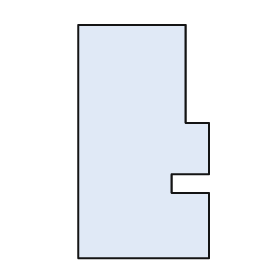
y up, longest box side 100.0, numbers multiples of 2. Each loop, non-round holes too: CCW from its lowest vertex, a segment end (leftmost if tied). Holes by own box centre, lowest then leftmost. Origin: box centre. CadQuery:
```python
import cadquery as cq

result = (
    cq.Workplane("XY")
    .moveTo(-28.0, -50.0)
    .lineTo(28.0, -50.0)
    .lineTo(28.0, -22.0)
    .lineTo(12.0, -22.0)
    .lineTo(12.0, -14.0)
    .lineTo(28.0, -14.0)
    .lineTo(28.0, 8.0)
    .lineTo(18.0, 8.0)
    .lineTo(18.0, 50.0)
    .lineTo(-28.0, 50.0)
    .close()
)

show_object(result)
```